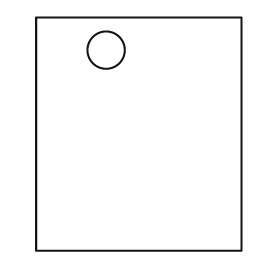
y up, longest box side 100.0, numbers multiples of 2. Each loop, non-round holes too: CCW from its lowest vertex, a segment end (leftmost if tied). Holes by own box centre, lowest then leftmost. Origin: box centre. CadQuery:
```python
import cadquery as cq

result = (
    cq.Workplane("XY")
    .moveTo(-44.0, -50.0)
    .lineTo(44.0, -50.0)
    .lineTo(44.0, 50.0)
    .lineTo(-44.0, 50.0)
    .close()
    .moveTo(-14.0, 36.0)
    .circle(8.0)
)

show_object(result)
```